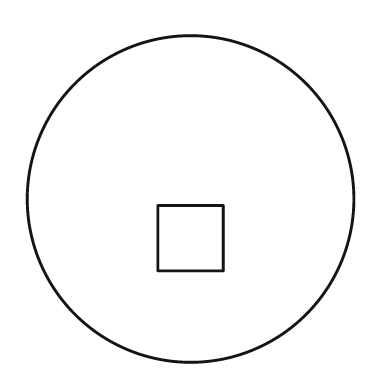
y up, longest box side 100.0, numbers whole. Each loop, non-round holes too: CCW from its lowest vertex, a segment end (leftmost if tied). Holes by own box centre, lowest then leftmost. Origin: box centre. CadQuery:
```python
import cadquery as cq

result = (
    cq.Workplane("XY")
    .moveTo(0.0, 0.0)
    .circle(50.0)
    .moveTo(-10.0, -22.0)
    .lineTo(10.0, -22.0)
    .lineTo(10.0, -2.0)
    .lineTo(-10.0, -2.0)
    .close()
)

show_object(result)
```